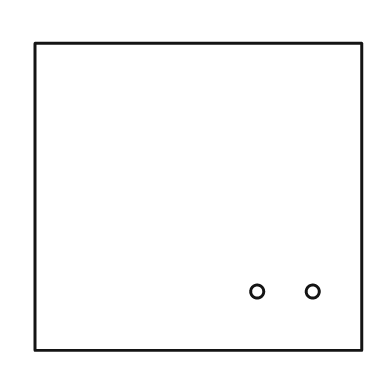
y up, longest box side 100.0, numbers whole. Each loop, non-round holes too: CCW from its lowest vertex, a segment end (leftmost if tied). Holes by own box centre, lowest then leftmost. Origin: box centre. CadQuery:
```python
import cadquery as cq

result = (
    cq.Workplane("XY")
    .moveTo(-50.0, -47.0)
    .lineTo(50.0, -47.0)
    .lineTo(50.0, 47.0)
    .lineTo(-50.0, 47.0)
    .close()
    .moveTo(18.0, -29.0)
    .circle(2.0)
    .moveTo(35.0, -29.0)
    .circle(2.0)
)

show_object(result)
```